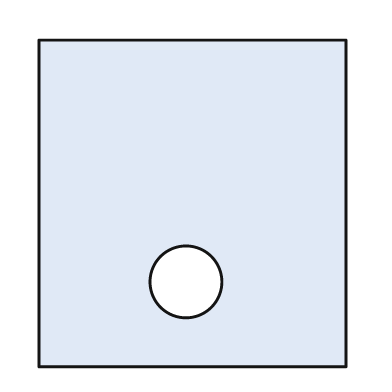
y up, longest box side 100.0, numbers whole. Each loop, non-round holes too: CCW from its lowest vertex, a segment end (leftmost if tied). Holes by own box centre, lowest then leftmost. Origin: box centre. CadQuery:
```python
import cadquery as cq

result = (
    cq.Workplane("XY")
    .moveTo(-47.0, -50.0)
    .lineTo(47.0, -50.0)
    .lineTo(47.0, 50.0)
    .lineTo(-47.0, 50.0)
    .close()
    .moveTo(-2.0, -24.0)
    .circle(11.0)
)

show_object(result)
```